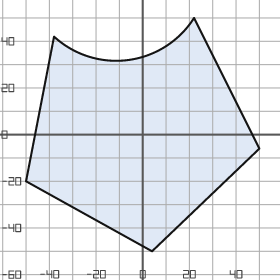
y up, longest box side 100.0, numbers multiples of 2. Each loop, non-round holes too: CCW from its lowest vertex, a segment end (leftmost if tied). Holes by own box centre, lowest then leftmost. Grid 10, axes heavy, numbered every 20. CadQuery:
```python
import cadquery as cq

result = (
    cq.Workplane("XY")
    .moveTo(4.0, -50.0)
    .lineTo(50.0, -6.0)
    .lineTo(22.0, 50.0)
    .threePointArc((-6.0, 32.0), (-38.0, 42.0))
    .lineTo(-50.0, -20.0)
    .close()
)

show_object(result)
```